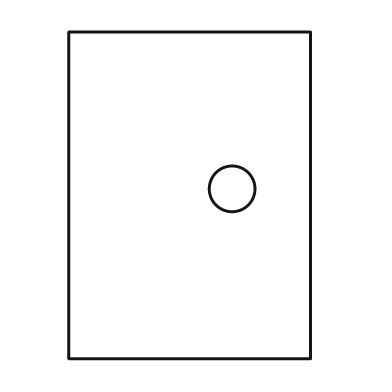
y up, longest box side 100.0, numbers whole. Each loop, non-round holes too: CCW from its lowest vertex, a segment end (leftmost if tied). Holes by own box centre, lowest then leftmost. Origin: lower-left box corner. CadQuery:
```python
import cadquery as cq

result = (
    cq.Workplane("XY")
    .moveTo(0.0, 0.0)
    .lineTo(74.0, 0.0)
    .lineTo(74.0, 100.0)
    .lineTo(0.0, 100.0)
    .close()
    .moveTo(50.0, 52.0)
    .circle(7.0)
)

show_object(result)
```